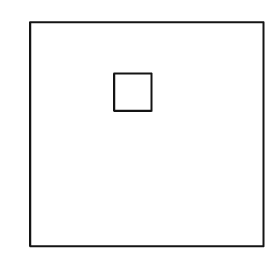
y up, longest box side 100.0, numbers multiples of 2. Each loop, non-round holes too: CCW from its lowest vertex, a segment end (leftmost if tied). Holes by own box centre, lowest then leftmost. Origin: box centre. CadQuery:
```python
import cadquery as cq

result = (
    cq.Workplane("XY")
    .moveTo(-50.0, -48.0)
    .lineTo(50.0, -48.0)
    .lineTo(50.0, 48.0)
    .lineTo(-50.0, 48.0)
    .close()
    .moveTo(-14.0, 10.0)
    .lineTo(2.0, 10.0)
    .lineTo(2.0, 26.0)
    .lineTo(-14.0, 26.0)
    .close()
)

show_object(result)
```